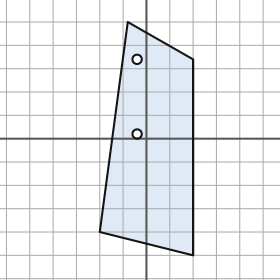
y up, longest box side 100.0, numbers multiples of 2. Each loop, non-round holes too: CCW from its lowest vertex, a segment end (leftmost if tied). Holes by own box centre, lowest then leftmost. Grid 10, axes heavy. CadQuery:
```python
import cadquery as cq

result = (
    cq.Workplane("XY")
    .moveTo(20.0, -50.0)
    .lineTo(20.0, 34.0)
    .lineTo(-8.0, 50.0)
    .lineTo(-20.0, -40.0)
    .close()
    .moveTo(-4.0, 2.0)
    .circle(2.0)
    .moveTo(-4.0, 34.0)
    .circle(2.0)
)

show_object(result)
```